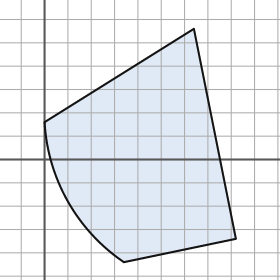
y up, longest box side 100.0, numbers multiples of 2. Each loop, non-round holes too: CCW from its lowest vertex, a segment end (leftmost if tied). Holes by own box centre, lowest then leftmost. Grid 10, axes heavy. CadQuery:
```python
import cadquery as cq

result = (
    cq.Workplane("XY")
    .moveTo(34.0, -44.0)
    .lineTo(82.0, -34.0)
    .lineTo(64.0, 56.0)
    .lineTo(0.0, 16.0)
    .threePointArc((10.0, -18.0), (34.0, -44.0))
    .close()
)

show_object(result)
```